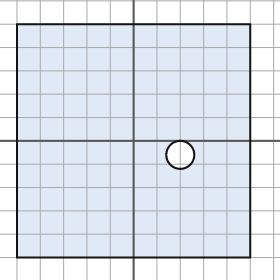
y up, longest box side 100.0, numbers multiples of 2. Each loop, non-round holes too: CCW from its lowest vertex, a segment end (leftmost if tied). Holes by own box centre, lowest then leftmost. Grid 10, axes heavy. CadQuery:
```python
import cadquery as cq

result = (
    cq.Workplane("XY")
    .moveTo(-50.0, -50.0)
    .lineTo(50.0, -50.0)
    .lineTo(50.0, 50.0)
    .lineTo(-50.0, 50.0)
    .close()
    .moveTo(20.0, -6.0)
    .circle(6.0)
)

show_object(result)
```